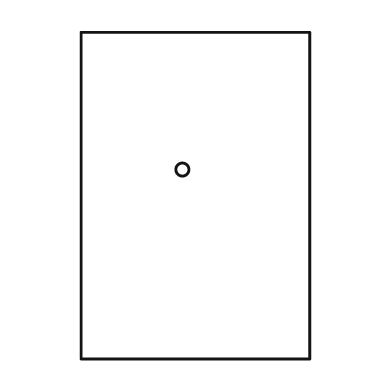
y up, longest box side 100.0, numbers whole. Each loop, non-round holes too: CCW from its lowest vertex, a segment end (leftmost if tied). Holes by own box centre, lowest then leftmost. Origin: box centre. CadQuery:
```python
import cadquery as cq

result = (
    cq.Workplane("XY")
    .moveTo(-35.0, -50.0)
    .lineTo(35.0, -50.0)
    .lineTo(35.0, 50.0)
    .lineTo(-35.0, 50.0)
    .close()
    .moveTo(-4.0, 8.0)
    .circle(2.0)
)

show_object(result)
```